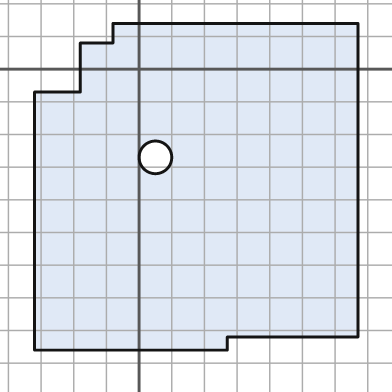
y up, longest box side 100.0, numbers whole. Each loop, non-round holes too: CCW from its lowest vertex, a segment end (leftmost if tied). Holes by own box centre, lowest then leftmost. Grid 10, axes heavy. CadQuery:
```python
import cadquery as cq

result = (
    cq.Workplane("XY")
    .moveTo(-32.0, -86.0)
    .lineTo(27.0, -86.0)
    .lineTo(27.0, -82.0)
    .lineTo(67.0, -82.0)
    .lineTo(67.0, 14.0)
    .lineTo(-8.0, 14.0)
    .lineTo(-8.0, 8.0)
    .lineTo(-18.0, 8.0)
    .lineTo(-18.0, -7.0)
    .lineTo(-32.0, -7.0)
    .close()
    .moveTo(5.0, -27.0)
    .circle(5.0)
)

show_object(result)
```